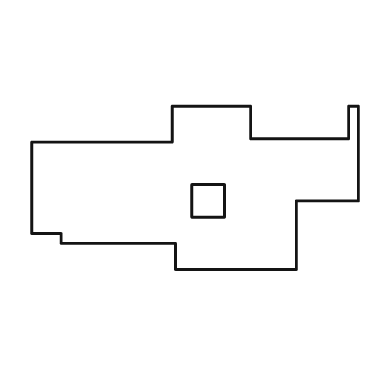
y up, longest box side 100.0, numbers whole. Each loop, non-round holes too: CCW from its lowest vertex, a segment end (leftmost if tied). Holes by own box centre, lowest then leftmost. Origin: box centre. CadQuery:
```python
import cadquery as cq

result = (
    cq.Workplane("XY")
    .moveTo(-6.0, -25.0)
    .lineTo(31.0, -25.0)
    .lineTo(31.0, -4.0)
    .lineTo(50.0, -4.0)
    .lineTo(50.0, 25.0)
    .lineTo(47.0, 25.0)
    .lineTo(47.0, 15.0)
    .lineTo(17.0, 15.0)
    .lineTo(17.0, 25.0)
    .lineTo(-7.0, 25.0)
    .lineTo(-7.0, 14.0)
    .lineTo(-50.0, 14.0)
    .lineTo(-50.0, -14.0)
    .lineTo(-41.0, -14.0)
    .lineTo(-41.0, -17.0)
    .lineTo(-6.0, -17.0)
    .close()
    .moveTo(-1.0, -9.0)
    .lineTo(9.0, -9.0)
    .lineTo(9.0, 1.0)
    .lineTo(-1.0, 1.0)
    .close()
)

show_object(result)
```